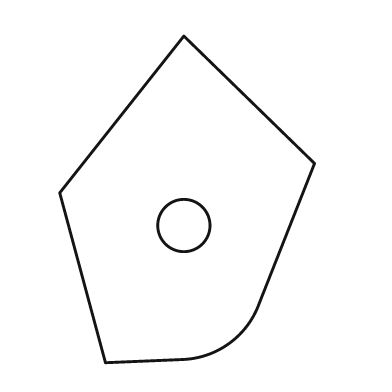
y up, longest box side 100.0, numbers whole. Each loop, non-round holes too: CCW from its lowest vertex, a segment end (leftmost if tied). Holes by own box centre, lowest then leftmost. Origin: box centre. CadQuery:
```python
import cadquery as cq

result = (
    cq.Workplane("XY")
    .moveTo(-25.0, -50.0)
    .lineTo(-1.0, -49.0)
    .threePointArc((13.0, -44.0), (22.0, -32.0))
    .lineTo(39.0, 11.0)
    .lineTo(-1.0, 50.0)
    .lineTo(-39.0, 2.0)
    .close()
    .moveTo(-1.0, -8.0)
    .circle(8.0)
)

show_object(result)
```